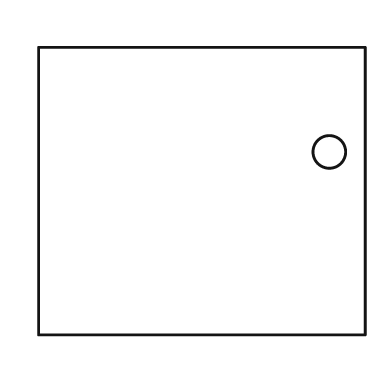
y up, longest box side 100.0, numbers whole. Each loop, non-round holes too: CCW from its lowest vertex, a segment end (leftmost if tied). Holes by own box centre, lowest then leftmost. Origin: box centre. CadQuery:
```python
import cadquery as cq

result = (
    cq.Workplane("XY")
    .moveTo(-50.0, -44.0)
    .lineTo(50.0, -44.0)
    .lineTo(50.0, 44.0)
    .lineTo(-50.0, 44.0)
    .close()
    .moveTo(39.0, 12.0)
    .circle(5.0)
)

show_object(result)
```